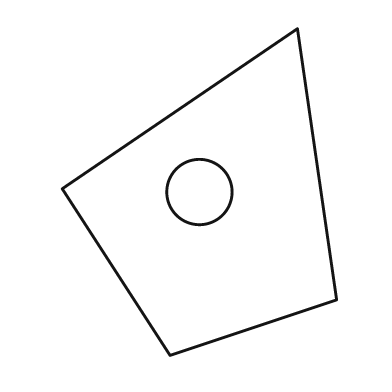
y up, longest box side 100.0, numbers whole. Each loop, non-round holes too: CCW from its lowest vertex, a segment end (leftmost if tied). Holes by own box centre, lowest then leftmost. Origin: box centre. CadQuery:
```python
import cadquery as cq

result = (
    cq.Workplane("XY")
    .moveTo(-9.0, -50.0)
    .lineTo(42.0, -33.0)
    .lineTo(30.0, 50.0)
    .lineTo(-42.0, 1.0)
    .close()
    .moveTo(0.0, 0.0)
    .circle(10.0)
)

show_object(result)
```